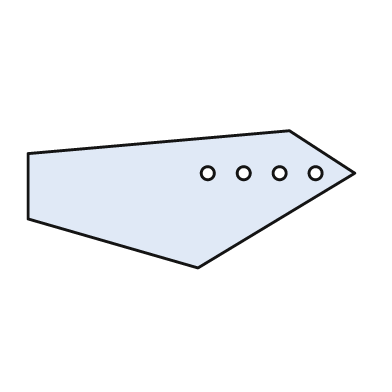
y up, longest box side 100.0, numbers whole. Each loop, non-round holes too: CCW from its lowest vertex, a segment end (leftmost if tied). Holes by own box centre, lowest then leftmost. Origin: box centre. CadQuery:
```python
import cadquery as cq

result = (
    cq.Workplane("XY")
    .moveTo(2.0, -21.0)
    .lineTo(50.0, 8.0)
    .lineTo(30.0, 21.0)
    .lineTo(-50.0, 14.0)
    .lineTo(-50.0, -6.0)
    .close()
    .moveTo(5.0, 8.0)
    .circle(2.0)
    .moveTo(16.0, 8.0)
    .circle(2.0)
    .moveTo(27.0, 8.0)
    .circle(2.0)
    .moveTo(38.0, 8.0)
    .circle(2.0)
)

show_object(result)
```